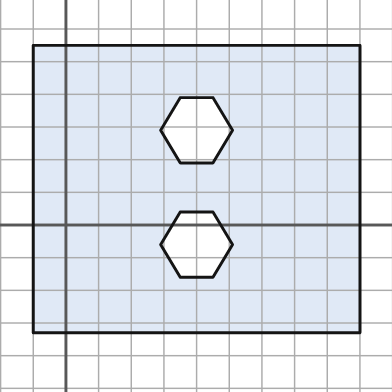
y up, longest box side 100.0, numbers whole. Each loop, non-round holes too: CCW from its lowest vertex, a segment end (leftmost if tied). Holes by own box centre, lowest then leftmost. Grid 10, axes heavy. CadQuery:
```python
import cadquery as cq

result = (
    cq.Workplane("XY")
    .moveTo(-10.0, -33.0)
    .lineTo(90.0, -33.0)
    .lineTo(90.0, 55.0)
    .lineTo(-10.0, 55.0)
    .close()
    .moveTo(35.0, -16.0)
    .lineTo(45.0, -16.0)
    .lineTo(51.0, -6.0)
    .lineTo(45.0, 4.0)
    .lineTo(35.0, 4.0)
    .lineTo(29.0, -6.0)
    .close()
    .moveTo(35.0, 19.0)
    .lineTo(45.0, 19.0)
    .lineTo(51.0, 29.0)
    .lineTo(45.0, 39.0)
    .lineTo(35.0, 39.0)
    .lineTo(29.0, 29.0)
    .close()
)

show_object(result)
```